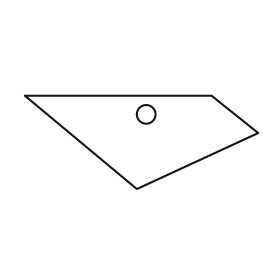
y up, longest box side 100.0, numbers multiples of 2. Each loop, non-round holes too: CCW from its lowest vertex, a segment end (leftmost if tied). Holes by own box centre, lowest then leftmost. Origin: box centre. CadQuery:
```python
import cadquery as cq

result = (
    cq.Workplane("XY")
    .moveTo(-2.0, -20.0)
    .lineTo(50.0, 4.0)
    .lineTo(30.0, 20.0)
    .lineTo(-50.0, 20.0)
    .close()
    .moveTo(2.0, 12.0)
    .circle(4.0)
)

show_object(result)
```